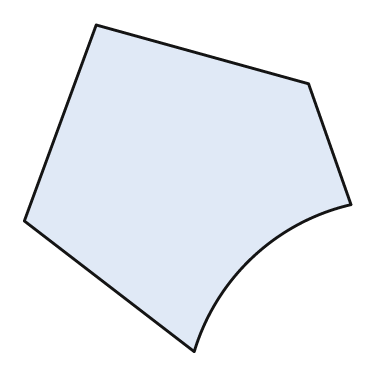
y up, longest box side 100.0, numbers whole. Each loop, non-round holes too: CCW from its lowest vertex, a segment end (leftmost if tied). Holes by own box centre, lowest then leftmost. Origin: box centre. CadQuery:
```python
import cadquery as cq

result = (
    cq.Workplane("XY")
    .moveTo(2.0, -50.0)
    .threePointArc((20.0, -21.0), (50.0, -5.0))
    .lineTo(37.0, 32.0)
    .lineTo(-28.0, 50.0)
    .lineTo(-50.0, -10.0)
    .close()
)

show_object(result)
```